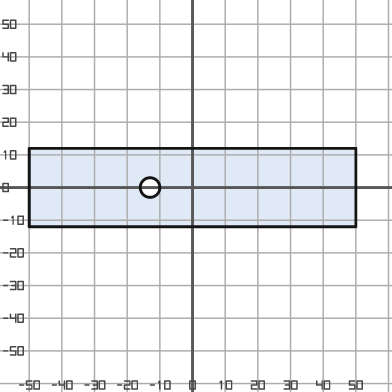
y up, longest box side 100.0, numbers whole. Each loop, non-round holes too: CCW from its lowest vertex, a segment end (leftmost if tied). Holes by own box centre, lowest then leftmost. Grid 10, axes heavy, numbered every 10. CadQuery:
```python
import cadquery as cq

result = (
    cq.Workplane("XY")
    .moveTo(-50.0, -12.0)
    .lineTo(50.0, -12.0)
    .lineTo(50.0, 12.0)
    .lineTo(-50.0, 12.0)
    .close()
    .moveTo(-13.0, 0.0)
    .circle(3.0)
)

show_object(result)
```